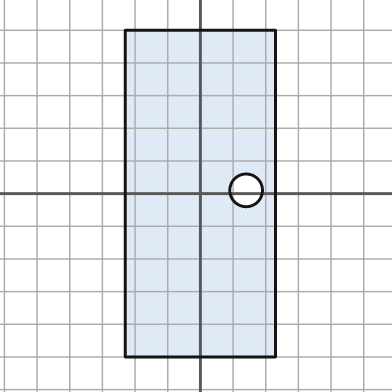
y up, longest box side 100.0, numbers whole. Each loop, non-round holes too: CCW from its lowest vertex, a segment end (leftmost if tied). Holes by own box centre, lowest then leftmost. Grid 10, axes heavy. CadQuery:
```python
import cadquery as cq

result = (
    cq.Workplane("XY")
    .moveTo(-23.0, -50.0)
    .lineTo(23.0, -50.0)
    .lineTo(23.0, 50.0)
    .lineTo(-23.0, 50.0)
    .close()
    .moveTo(14.0, 1.0)
    .circle(5.0)
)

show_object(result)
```